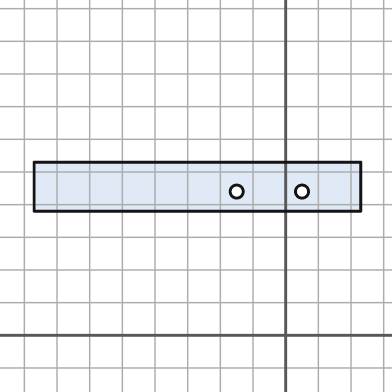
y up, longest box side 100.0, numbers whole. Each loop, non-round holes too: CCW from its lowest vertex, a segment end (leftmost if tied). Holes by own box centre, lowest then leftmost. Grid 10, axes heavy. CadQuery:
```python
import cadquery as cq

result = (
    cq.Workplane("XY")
    .moveTo(-77.0, 38.0)
    .lineTo(23.0, 38.0)
    .lineTo(23.0, 53.0)
    .lineTo(-77.0, 53.0)
    .close()
    .moveTo(-15.0, 44.0)
    .circle(2.0)
    .moveTo(5.0, 44.0)
    .circle(2.0)
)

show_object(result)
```